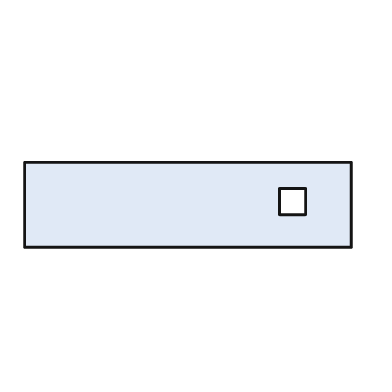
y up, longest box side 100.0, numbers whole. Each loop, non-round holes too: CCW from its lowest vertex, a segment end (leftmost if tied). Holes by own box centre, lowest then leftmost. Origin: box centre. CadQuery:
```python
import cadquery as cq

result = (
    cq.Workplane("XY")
    .moveTo(-50.0, -13.0)
    .lineTo(50.0, -13.0)
    .lineTo(50.0, 13.0)
    .lineTo(-50.0, 13.0)
    .close()
    .moveTo(28.0, -3.0)
    .lineTo(36.0, -3.0)
    .lineTo(36.0, 5.0)
    .lineTo(28.0, 5.0)
    .close()
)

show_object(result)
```